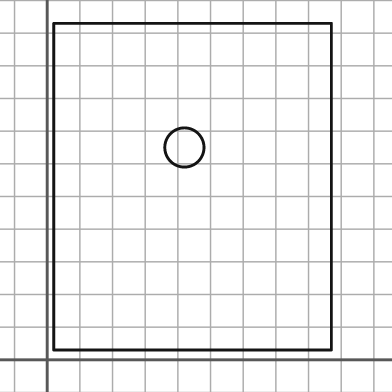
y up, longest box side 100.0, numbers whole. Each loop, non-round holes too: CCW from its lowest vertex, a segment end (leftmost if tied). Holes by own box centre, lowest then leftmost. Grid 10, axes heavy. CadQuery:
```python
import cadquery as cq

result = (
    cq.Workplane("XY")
    .moveTo(2.0, 3.0)
    .lineTo(87.0, 3.0)
    .lineTo(87.0, 103.0)
    .lineTo(2.0, 103.0)
    .close()
    .moveTo(42.0, 65.0)
    .circle(6.0)
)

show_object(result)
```